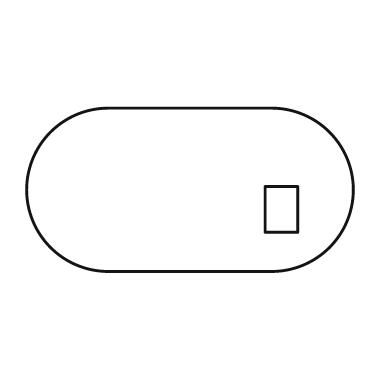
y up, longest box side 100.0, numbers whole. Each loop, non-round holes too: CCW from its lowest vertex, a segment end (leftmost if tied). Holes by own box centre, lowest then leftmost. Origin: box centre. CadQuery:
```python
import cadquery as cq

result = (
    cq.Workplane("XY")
    .moveTo(-25.0, -25.0)
    .lineTo(25.0, -25.0)
    .threePointArc((50.0, 0.0), (25.0, 25.0))
    .lineTo(-25.0, 25.0)
    .threePointArc((-50.0, 0.0), (-25.0, -25.0))
    .close()
    .moveTo(23.0, -13.0)
    .lineTo(33.0, -13.0)
    .lineTo(33.0, 1.0)
    .lineTo(23.0, 1.0)
    .close()
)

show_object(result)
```